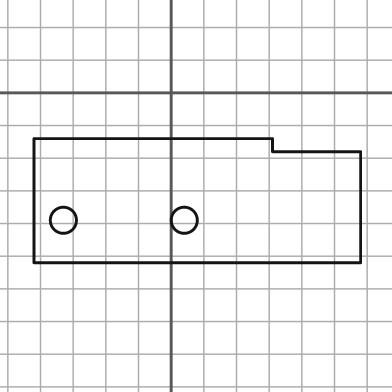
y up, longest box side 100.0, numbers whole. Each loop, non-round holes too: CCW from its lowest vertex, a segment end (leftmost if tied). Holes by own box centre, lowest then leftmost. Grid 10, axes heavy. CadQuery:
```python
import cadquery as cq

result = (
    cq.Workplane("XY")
    .moveTo(-42.0, -52.0)
    .lineTo(58.0, -52.0)
    .lineTo(58.0, -18.0)
    .lineTo(31.0, -18.0)
    .lineTo(31.0, -14.0)
    .lineTo(-42.0, -14.0)
    .close()
    .moveTo(-33.0, -39.0)
    .circle(4.0)
    .moveTo(4.0, -39.0)
    .circle(4.0)
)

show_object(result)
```